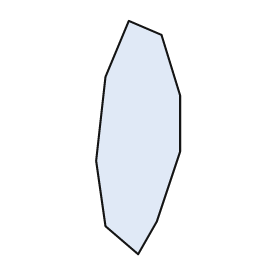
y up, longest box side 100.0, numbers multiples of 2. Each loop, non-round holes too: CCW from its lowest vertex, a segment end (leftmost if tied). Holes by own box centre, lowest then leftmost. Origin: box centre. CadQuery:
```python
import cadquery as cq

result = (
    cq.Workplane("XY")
    .moveTo(0.0, -50.0)
    .lineTo(8.0, -36.0)
    .lineTo(18.0, -6.0)
    .lineTo(18.0, 18.0)
    .lineTo(10.0, 44.0)
    .lineTo(-4.0, 50.0)
    .lineTo(-14.0, 26.0)
    .lineTo(-18.0, -10.0)
    .lineTo(-14.0, -38.0)
    .close()
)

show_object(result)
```